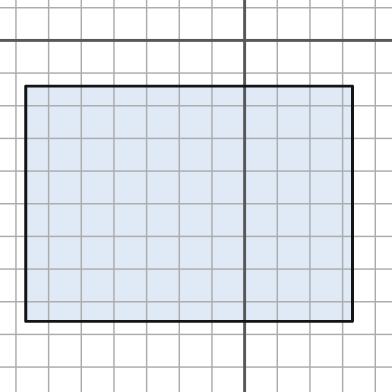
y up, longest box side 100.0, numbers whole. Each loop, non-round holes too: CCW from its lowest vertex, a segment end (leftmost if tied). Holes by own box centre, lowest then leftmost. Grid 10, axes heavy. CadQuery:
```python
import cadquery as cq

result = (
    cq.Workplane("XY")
    .moveTo(-67.0, -86.0)
    .lineTo(33.0, -86.0)
    .lineTo(33.0, -14.0)
    .lineTo(-67.0, -14.0)
    .close()
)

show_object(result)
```